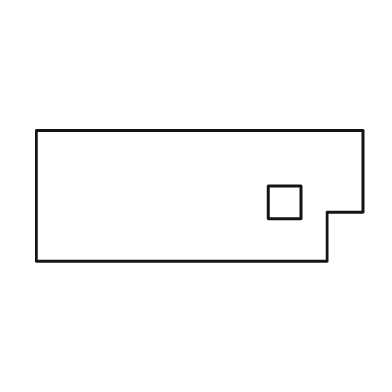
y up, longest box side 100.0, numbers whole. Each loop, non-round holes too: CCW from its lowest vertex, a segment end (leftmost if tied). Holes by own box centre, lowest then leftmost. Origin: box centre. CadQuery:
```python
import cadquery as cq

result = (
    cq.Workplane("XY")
    .moveTo(-50.0, -20.0)
    .lineTo(39.0, -20.0)
    .lineTo(39.0, -5.0)
    .lineTo(50.0, -5.0)
    .lineTo(50.0, 20.0)
    .lineTo(-50.0, 20.0)
    .close()
    .moveTo(21.0, -7.0)
    .lineTo(31.0, -7.0)
    .lineTo(31.0, 3.0)
    .lineTo(21.0, 3.0)
    .close()
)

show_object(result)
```